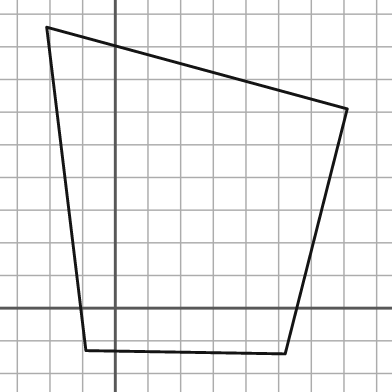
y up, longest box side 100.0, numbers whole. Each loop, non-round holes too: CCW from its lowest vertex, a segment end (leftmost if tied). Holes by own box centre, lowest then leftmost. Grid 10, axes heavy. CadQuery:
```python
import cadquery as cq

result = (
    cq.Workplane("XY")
    .moveTo(52.0, -14.0)
    .lineTo(71.0, 61.0)
    .lineTo(-21.0, 86.0)
    .lineTo(-9.0, -13.0)
    .close()
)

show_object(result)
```